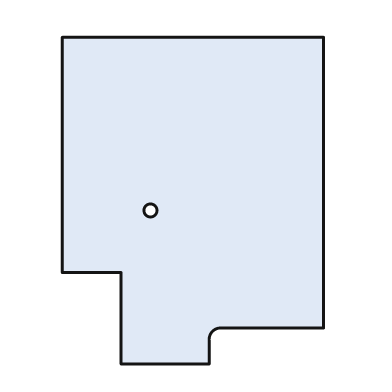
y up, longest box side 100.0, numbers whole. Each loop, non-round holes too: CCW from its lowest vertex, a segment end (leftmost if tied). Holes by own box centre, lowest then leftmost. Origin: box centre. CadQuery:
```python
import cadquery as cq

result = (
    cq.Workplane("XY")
    .moveTo(-22.0, -50.0)
    .lineTo(5.0, -50.0)
    .lineTo(5.0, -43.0)
    .threePointArc((6.0, -40.0), (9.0, -39.0))
    .lineTo(40.0, -39.0)
    .lineTo(40.0, 50.0)
    .lineTo(-40.0, 50.0)
    .lineTo(-40.0, -22.0)
    .lineTo(-22.0, -22.0)
    .close()
    .moveTo(-13.0, -3.0)
    .circle(2.0)
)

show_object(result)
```